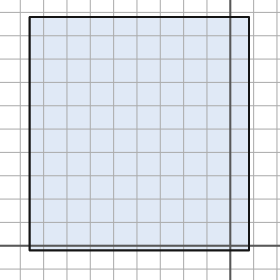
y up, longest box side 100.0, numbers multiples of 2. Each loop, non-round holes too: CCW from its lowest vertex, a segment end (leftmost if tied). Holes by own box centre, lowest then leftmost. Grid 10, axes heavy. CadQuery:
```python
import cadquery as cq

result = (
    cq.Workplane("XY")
    .moveTo(-86.0, -2.0)
    .lineTo(8.0, -2.0)
    .lineTo(8.0, 98.0)
    .lineTo(-86.0, 98.0)
    .close()
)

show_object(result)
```